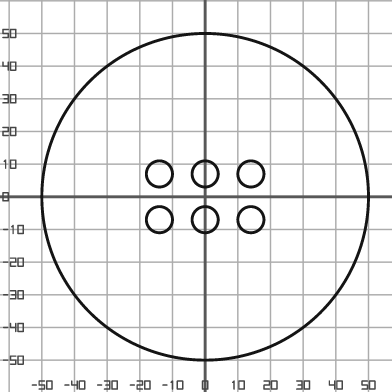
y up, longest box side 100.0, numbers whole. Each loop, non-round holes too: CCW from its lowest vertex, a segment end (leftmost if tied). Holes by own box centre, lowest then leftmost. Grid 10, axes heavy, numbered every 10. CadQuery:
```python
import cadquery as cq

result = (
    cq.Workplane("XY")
    .moveTo(0.0, 0.0)
    .circle(50.0)
    .moveTo(-14.0, -7.0)
    .circle(4.0)
    .moveTo(0.0, -7.0)
    .circle(4.0)
    .moveTo(14.0, -7.0)
    .circle(4.0)
    .moveTo(-14.0, 7.0)
    .circle(4.0)
    .moveTo(0.0, 7.0)
    .circle(4.0)
    .moveTo(14.0, 7.0)
    .circle(4.0)
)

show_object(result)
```